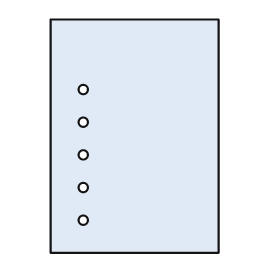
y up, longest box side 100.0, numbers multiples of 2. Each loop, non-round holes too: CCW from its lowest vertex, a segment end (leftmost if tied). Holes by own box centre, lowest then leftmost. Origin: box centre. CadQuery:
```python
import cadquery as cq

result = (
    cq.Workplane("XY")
    .moveTo(-36.0, -50.0)
    .lineTo(36.0, -50.0)
    .lineTo(36.0, 50.0)
    .lineTo(-36.0, 50.0)
    .close()
    .moveTo(-22.0, -36.0)
    .circle(2.0)
    .moveTo(-22.0, -22.0)
    .circle(2.0)
    .moveTo(-22.0, -8.0)
    .circle(2.0)
    .moveTo(-22.0, 6.0)
    .circle(2.0)
    .moveTo(-22.0, 20.0)
    .circle(2.0)
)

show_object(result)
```